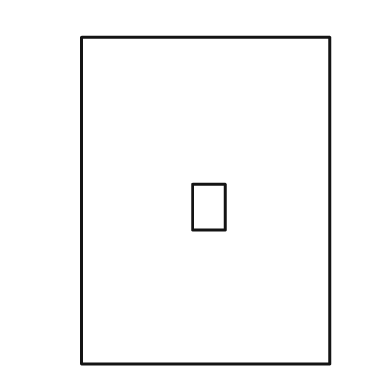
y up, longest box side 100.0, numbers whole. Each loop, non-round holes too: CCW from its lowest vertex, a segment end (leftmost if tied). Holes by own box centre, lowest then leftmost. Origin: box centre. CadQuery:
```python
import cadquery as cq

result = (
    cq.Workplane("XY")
    .moveTo(-38.0, -50.0)
    .lineTo(38.0, -50.0)
    .lineTo(38.0, 50.0)
    .lineTo(-38.0, 50.0)
    .close()
    .moveTo(-4.0, -9.0)
    .lineTo(6.0, -9.0)
    .lineTo(6.0, 5.0)
    .lineTo(-4.0, 5.0)
    .close()
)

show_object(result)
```